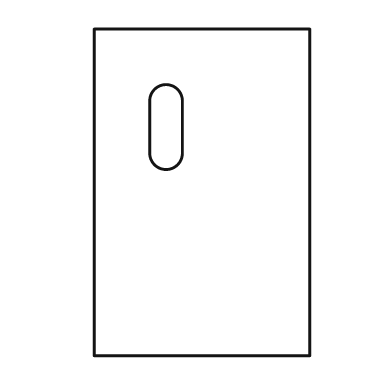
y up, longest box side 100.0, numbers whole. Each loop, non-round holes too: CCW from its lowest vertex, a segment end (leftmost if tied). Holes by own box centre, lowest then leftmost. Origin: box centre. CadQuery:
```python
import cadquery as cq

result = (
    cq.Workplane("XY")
    .moveTo(-33.0, -50.0)
    .lineTo(33.0, -50.0)
    .lineTo(33.0, 50.0)
    .lineTo(-33.0, 50.0)
    .close()
    .moveTo(-16.0, 12.0)
    .threePointArc((-11.0, 7.0), (-6.0, 12.0))
    .lineTo(-6.0, 28.0)
    .threePointArc((-11.0, 33.0), (-16.0, 28.0))
    .close()
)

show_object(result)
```